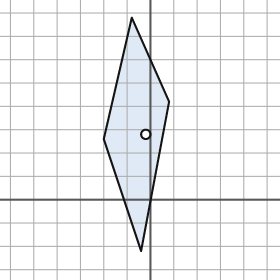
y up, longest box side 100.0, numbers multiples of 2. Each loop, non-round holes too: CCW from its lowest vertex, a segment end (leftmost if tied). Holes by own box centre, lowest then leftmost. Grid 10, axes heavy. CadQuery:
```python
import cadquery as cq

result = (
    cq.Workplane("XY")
    .moveTo(-4.0, -22.0)
    .lineTo(8.0, 42.0)
    .lineTo(-8.0, 78.0)
    .lineTo(-20.0, 26.0)
    .close()
    .moveTo(-2.0, 28.0)
    .circle(2.0)
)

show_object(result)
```